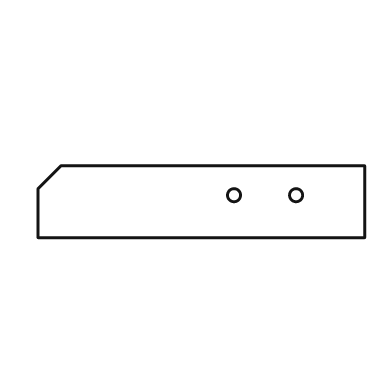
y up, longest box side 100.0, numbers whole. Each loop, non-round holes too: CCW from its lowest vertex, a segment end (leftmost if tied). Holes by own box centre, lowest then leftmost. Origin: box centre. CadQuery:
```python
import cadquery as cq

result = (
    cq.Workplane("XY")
    .moveTo(-50.0, -11.0)
    .lineTo(50.0, -11.0)
    .lineTo(50.0, 11.0)
    .lineTo(-43.0, 11.0)
    .lineTo(-50.0, 4.0)
    .close()
    .moveTo(10.0, 2.0)
    .circle(2.0)
    .moveTo(29.0, 2.0)
    .circle(2.0)
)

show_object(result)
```